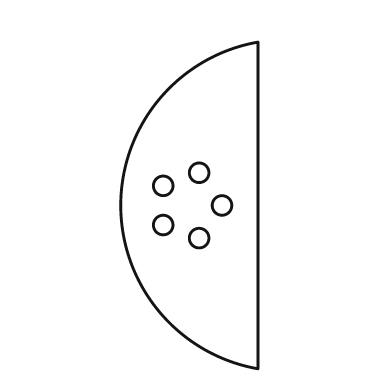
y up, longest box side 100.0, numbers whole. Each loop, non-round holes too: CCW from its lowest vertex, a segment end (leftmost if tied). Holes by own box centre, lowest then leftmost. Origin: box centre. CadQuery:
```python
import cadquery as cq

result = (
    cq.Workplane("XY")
    .moveTo(21.0, -50.0)
    .lineTo(21.0, 50.0)
    .threePointArc((-21.0, 0.0), (21.0, -50.0))
    .close()
    .moveTo(3.0, -10.0)
    .circle(3.0)
    .moveTo(-8.0, -6.0)
    .circle(3.0)
    .moveTo(10.0, 0.0)
    .circle(3.0)
    .moveTo(-8.0, 6.0)
    .circle(3.0)
    .moveTo(3.0, 10.0)
    .circle(3.0)
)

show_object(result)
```